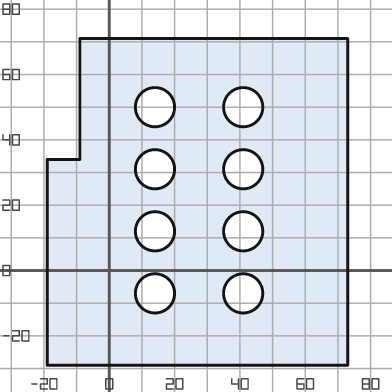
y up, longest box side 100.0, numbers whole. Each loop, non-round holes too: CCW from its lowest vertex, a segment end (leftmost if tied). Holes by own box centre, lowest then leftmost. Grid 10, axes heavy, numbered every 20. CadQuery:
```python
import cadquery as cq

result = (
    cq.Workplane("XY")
    .moveTo(-19.0, -29.0)
    .lineTo(73.0, -29.0)
    .lineTo(73.0, 71.0)
    .lineTo(-9.0, 71.0)
    .lineTo(-9.0, 34.0)
    .lineTo(-19.0, 34.0)
    .close()
    .moveTo(14.0, -7.0)
    .circle(6.0)
    .moveTo(41.0, -7.0)
    .circle(6.0)
    .moveTo(14.0, 12.0)
    .circle(6.0)
    .moveTo(41.0, 12.0)
    .circle(6.0)
    .moveTo(14.0, 31.0)
    .circle(6.0)
    .moveTo(41.0, 31.0)
    .circle(6.0)
    .moveTo(14.0, 50.0)
    .circle(6.0)
    .moveTo(41.0, 50.0)
    .circle(6.0)
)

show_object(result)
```